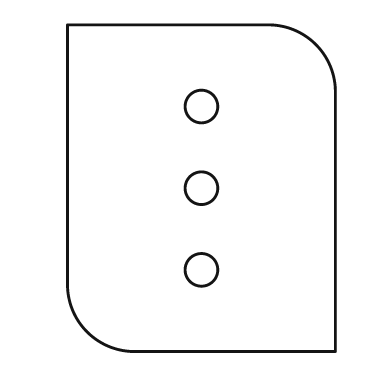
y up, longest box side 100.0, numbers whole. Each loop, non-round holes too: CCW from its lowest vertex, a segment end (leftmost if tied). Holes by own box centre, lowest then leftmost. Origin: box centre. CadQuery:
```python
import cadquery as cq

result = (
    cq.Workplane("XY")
    .moveTo(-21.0, -50.0)
    .lineTo(41.0, -50.0)
    .lineTo(41.0, 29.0)
    .threePointArc((35.0, 44.0), (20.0, 50.0))
    .lineTo(-41.0, 50.0)
    .lineTo(-41.0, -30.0)
    .threePointArc((-35.0, -44.0), (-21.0, -50.0))
    .close()
    .moveTo(0.0, -25.0)
    .circle(5.0)
    .moveTo(0.0, 0.0)
    .circle(5.0)
    .moveTo(0.0, 25.0)
    .circle(5.0)
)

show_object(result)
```